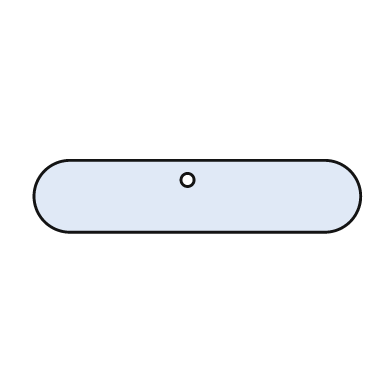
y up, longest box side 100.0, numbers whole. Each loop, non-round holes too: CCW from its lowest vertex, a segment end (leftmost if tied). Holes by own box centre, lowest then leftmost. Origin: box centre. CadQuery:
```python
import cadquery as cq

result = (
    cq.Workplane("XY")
    .moveTo(-39.0, -11.0)
    .lineTo(39.0, -11.0)
    .threePointArc((50.0, 0.0), (39.0, 11.0))
    .lineTo(-39.0, 11.0)
    .threePointArc((-50.0, 0.0), (-39.0, -11.0))
    .close()
    .moveTo(-3.0, 5.0)
    .circle(2.0)
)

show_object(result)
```